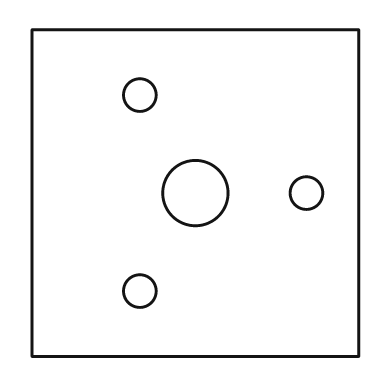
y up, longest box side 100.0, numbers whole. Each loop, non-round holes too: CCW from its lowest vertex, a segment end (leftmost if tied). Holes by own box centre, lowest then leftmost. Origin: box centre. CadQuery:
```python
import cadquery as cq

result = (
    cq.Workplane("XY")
    .moveTo(-50.0, -50.0)
    .lineTo(50.0, -50.0)
    .lineTo(50.0, 50.0)
    .lineTo(-50.0, 50.0)
    .close()
    .moveTo(-17.0, -30.0)
    .circle(5.0)
    .moveTo(0.0, 0.0)
    .circle(10.0)
    .moveTo(34.0, 0.0)
    .circle(5.0)
    .moveTo(-17.0, 30.0)
    .circle(5.0)
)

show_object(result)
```